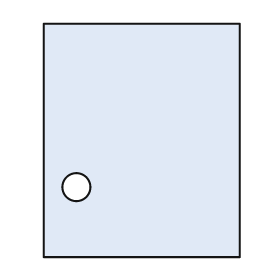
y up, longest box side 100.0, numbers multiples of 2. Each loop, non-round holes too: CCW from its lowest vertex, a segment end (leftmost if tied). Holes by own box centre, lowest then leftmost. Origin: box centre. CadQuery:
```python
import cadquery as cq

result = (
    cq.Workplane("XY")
    .moveTo(-42.0, -50.0)
    .lineTo(42.0, -50.0)
    .lineTo(42.0, 50.0)
    .lineTo(-42.0, 50.0)
    .close()
    .moveTo(-28.0, -20.0)
    .circle(6.0)
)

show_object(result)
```